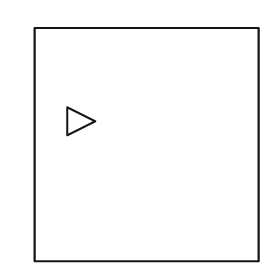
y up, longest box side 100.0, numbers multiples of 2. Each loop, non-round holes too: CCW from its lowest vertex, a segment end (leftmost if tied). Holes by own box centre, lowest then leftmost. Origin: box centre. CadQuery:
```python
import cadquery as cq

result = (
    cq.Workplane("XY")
    .moveTo(-48.0, -50.0)
    .lineTo(48.0, -50.0)
    .lineTo(48.0, 50.0)
    .lineTo(-48.0, 50.0)
    .close()
    .moveTo(-34.0, 4.0)
    .lineTo(-22.0, 10.0)
    .lineTo(-34.0, 16.0)
    .close()
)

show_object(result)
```